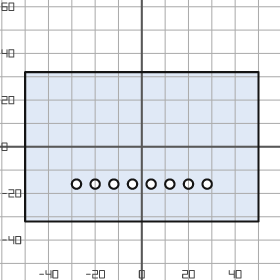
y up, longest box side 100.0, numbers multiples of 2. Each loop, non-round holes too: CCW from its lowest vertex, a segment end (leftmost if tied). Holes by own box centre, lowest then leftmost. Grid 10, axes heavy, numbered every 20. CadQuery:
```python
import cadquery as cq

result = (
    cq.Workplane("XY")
    .moveTo(-50.0, -32.0)
    .lineTo(50.0, -32.0)
    .lineTo(50.0, 32.0)
    .lineTo(-50.0, 32.0)
    .close()
    .moveTo(-28.0, -16.0)
    .circle(2.0)
    .moveTo(-20.0, -16.0)
    .circle(2.0)
    .moveTo(-12.0, -16.0)
    .circle(2.0)
    .moveTo(-4.0, -16.0)
    .circle(2.0)
    .moveTo(4.0, -16.0)
    .circle(2.0)
    .moveTo(12.0, -16.0)
    .circle(2.0)
    .moveTo(20.0, -16.0)
    .circle(2.0)
    .moveTo(28.0, -16.0)
    .circle(2.0)
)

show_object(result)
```